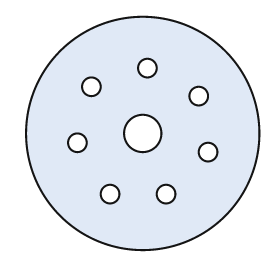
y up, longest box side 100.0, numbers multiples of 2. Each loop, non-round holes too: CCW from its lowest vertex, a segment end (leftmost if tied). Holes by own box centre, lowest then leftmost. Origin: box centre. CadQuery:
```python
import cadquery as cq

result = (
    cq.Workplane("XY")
    .moveTo(0.0, 0.0)
    .circle(50.0)
    .moveTo(-14.0, -26.0)
    .circle(4.0)
    .moveTo(10.0, -26.0)
    .circle(4.0)
    .moveTo(28.0, -8.0)
    .circle(4.0)
    .moveTo(-28.0, -4.0)
    .circle(4.0)
    .moveTo(0.0, 0.0)
    .circle(8.0)
    .moveTo(24.0, 16.0)
    .circle(4.0)
    .moveTo(-22.0, 20.0)
    .circle(4.0)
    .moveTo(2.0, 28.0)
    .circle(4.0)
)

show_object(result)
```